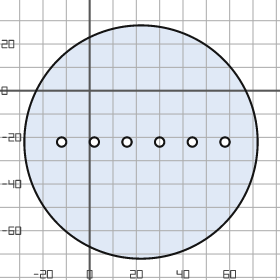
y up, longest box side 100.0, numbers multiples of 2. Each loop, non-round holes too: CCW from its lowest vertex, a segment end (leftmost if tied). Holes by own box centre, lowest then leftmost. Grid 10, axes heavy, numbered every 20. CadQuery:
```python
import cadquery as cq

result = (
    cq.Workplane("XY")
    .moveTo(22.0, -22.0)
    .circle(50.0)
    .moveTo(-12.0, -22.0)
    .circle(2.0)
    .moveTo(2.0, -22.0)
    .circle(2.0)
    .moveTo(16.0, -22.0)
    .circle(2.0)
    .moveTo(30.0, -22.0)
    .circle(2.0)
    .moveTo(44.0, -22.0)
    .circle(2.0)
    .moveTo(58.0, -22.0)
    .circle(2.0)
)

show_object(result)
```